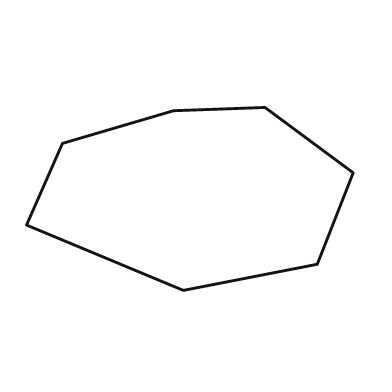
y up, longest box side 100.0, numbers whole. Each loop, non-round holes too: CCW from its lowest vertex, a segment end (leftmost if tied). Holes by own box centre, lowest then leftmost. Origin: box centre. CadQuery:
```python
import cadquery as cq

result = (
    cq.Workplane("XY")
    .moveTo(-2.0, -28.0)
    .lineTo(39.0, -20.0)
    .lineTo(50.0, 8.0)
    .lineTo(23.0, 28.0)
    .lineTo(-5.0, 27.0)
    .lineTo(-39.0, 17.0)
    .lineTo(-50.0, -8.0)
    .close()
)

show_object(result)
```